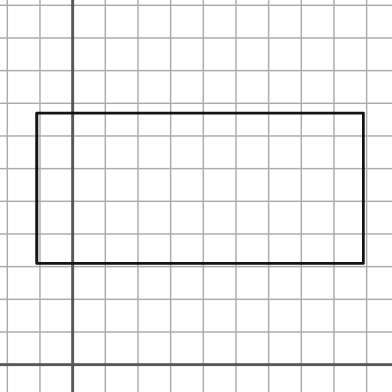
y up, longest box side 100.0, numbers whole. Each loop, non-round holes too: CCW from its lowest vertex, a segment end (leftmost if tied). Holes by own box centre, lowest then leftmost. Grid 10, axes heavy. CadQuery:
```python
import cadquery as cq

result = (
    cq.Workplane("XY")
    .moveTo(-11.0, 31.0)
    .lineTo(89.0, 31.0)
    .lineTo(89.0, 77.0)
    .lineTo(-11.0, 77.0)
    .close()
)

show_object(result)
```